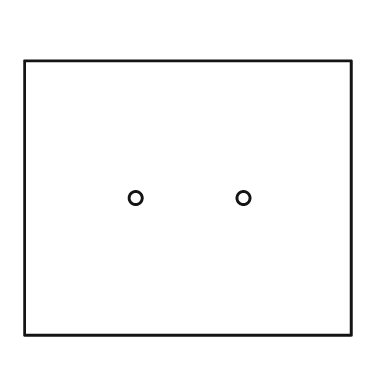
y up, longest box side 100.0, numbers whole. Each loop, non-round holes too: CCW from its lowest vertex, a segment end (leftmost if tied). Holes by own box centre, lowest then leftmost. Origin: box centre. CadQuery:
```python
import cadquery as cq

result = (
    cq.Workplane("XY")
    .moveTo(-50.0, -42.0)
    .lineTo(50.0, -42.0)
    .lineTo(50.0, 42.0)
    .lineTo(-50.0, 42.0)
    .close()
    .moveTo(-16.0, 0.0)
    .circle(2.0)
    .moveTo(17.0, 0.0)
    .circle(2.0)
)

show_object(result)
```